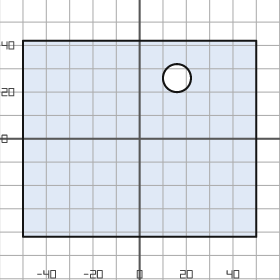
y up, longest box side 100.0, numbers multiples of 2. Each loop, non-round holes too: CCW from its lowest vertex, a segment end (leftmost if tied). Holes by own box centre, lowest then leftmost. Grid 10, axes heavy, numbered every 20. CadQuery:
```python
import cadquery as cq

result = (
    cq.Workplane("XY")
    .moveTo(-50.0, -42.0)
    .lineTo(50.0, -42.0)
    .lineTo(50.0, 42.0)
    .lineTo(-50.0, 42.0)
    .close()
    .moveTo(16.0, 26.0)
    .circle(6.0)
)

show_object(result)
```